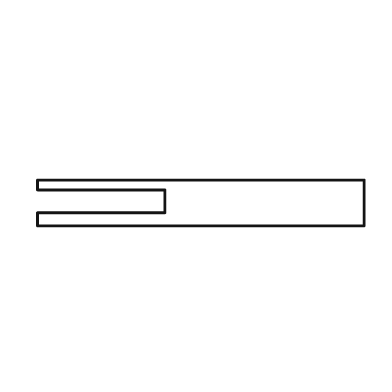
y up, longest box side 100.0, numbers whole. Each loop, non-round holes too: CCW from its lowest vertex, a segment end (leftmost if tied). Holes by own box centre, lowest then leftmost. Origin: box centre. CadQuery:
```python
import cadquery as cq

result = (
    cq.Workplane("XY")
    .moveTo(-50.0, -7.0)
    .lineTo(50.0, -7.0)
    .lineTo(50.0, 7.0)
    .lineTo(-50.0, 7.0)
    .lineTo(-50.0, 4.0)
    .lineTo(-11.0, 4.0)
    .lineTo(-11.0, -3.0)
    .lineTo(-50.0, -3.0)
    .close()
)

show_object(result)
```